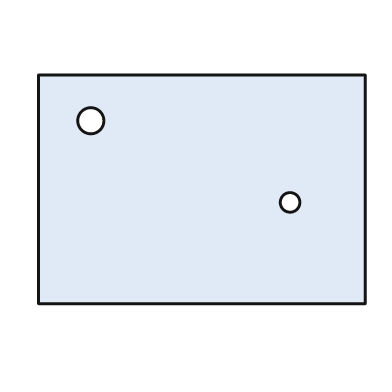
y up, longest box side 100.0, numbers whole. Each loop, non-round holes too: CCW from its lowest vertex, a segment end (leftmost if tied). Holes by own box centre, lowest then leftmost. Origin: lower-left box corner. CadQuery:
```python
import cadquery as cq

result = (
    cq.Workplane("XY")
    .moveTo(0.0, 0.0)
    .lineTo(100.0, 0.0)
    .lineTo(100.0, 70.0)
    .lineTo(0.0, 70.0)
    .close()
    .moveTo(77.0, 31.0)
    .circle(3.0)
    .moveTo(16.0, 56.0)
    .circle(4.0)
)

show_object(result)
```